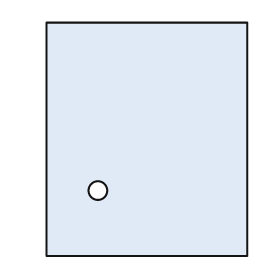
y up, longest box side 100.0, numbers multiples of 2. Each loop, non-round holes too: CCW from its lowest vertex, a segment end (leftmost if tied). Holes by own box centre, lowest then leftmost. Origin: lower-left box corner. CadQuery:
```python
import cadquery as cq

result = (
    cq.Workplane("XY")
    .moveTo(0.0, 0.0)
    .lineTo(86.0, 0.0)
    .lineTo(86.0, 100.0)
    .lineTo(0.0, 100.0)
    .close()
    .moveTo(22.0, 28.0)
    .circle(4.0)
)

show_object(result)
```